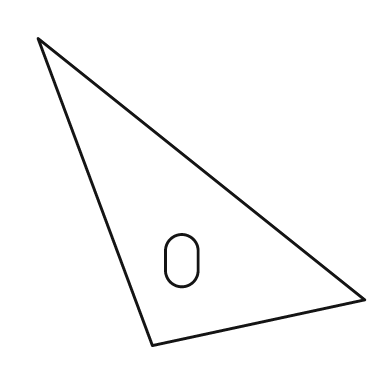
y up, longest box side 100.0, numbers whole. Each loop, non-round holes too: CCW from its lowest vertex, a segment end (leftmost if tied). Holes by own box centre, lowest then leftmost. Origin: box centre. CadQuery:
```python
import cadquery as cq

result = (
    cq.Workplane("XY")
    .moveTo(-15.0, -47.0)
    .lineTo(50.0, -33.0)
    .lineTo(-50.0, 47.0)
    .close()
    .moveTo(-11.0, -24.0)
    .threePointArc((-6.0, -29.0), (-1.0, -24.0))
    .lineTo(-1.0, -18.0)
    .threePointArc((-6.0, -13.0), (-11.0, -18.0))
    .close()
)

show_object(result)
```